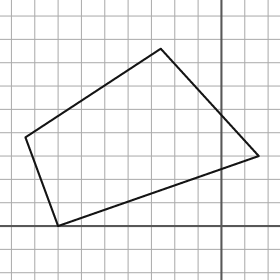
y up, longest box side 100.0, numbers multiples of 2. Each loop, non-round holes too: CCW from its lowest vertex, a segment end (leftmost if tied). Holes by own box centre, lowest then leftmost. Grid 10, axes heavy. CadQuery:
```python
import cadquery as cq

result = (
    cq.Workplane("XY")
    .moveTo(-70.0, 0.0)
    .lineTo(16.0, 30.0)
    .lineTo(-26.0, 76.0)
    .lineTo(-84.0, 38.0)
    .close()
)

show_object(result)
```